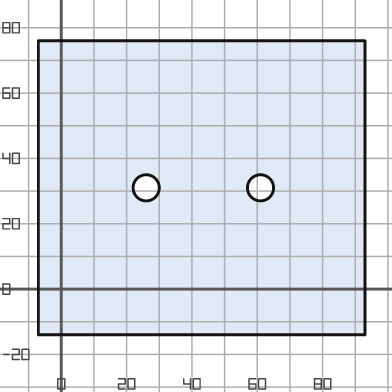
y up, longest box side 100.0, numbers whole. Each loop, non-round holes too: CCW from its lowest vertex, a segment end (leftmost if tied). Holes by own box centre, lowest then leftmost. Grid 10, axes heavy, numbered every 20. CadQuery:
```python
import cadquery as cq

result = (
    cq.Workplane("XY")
    .moveTo(-7.0, -14.0)
    .lineTo(93.0, -14.0)
    .lineTo(93.0, 76.0)
    .lineTo(-7.0, 76.0)
    .close()
    .moveTo(26.0, 31.0)
    .circle(4.0)
    .moveTo(61.0, 31.0)
    .circle(4.0)
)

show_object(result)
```